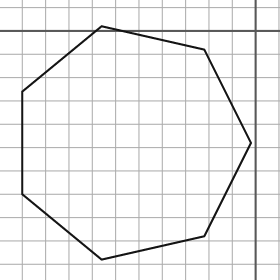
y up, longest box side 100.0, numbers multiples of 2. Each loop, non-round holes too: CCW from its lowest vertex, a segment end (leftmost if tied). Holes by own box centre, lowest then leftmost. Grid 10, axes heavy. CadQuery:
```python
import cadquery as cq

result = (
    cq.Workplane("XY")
    .moveTo(-66.0, -98.0)
    .lineTo(-22.0, -88.0)
    .lineTo(-2.0, -48.0)
    .lineTo(-22.0, -8.0)
    .lineTo(-66.0, 2.0)
    .lineTo(-100.0, -26.0)
    .lineTo(-100.0, -70.0)
    .close()
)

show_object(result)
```